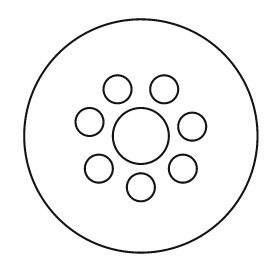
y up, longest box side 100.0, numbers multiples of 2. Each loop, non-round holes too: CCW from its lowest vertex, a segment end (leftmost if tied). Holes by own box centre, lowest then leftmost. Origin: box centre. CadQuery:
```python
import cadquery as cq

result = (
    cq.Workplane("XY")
    .moveTo(0.0, 0.0)
    .circle(50.0)
    .moveTo(0.0, -22.0)
    .circle(6.0)
    .moveTo(-18.0, -14.0)
    .circle(6.0)
    .moveTo(18.0, -14.0)
    .circle(6.0)
    .moveTo(0.0, 0.0)
    .circle(12.0)
    .moveTo(22.0, 4.0)
    .circle(6.0)
    .moveTo(-22.0, 6.0)
    .circle(6.0)
    .moveTo(-10.0, 20.0)
    .circle(6.0)
    .moveTo(10.0, 20.0)
    .circle(6.0)
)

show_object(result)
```